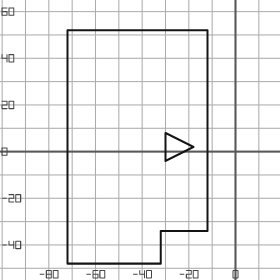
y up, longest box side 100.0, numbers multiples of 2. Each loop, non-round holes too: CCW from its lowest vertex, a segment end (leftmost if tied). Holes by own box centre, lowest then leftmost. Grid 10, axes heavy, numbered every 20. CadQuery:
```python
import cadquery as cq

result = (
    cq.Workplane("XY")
    .moveTo(-72.0, -48.0)
    .lineTo(-32.0, -48.0)
    .lineTo(-32.0, -34.0)
    .lineTo(-12.0, -34.0)
    .lineTo(-12.0, 52.0)
    .lineTo(-72.0, 52.0)
    .close()
    .moveTo(-30.0, -4.0)
    .lineTo(-18.0, 2.0)
    .lineTo(-30.0, 8.0)
    .close()
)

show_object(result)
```